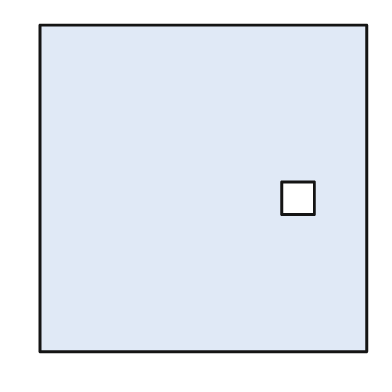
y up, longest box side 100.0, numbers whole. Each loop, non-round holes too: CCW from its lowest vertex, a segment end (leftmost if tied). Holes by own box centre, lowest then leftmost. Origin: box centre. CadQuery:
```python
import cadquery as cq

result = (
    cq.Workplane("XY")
    .moveTo(-50.0, -50.0)
    .lineTo(50.0, -50.0)
    .lineTo(50.0, 50.0)
    .lineTo(-50.0, 50.0)
    .close()
    .moveTo(24.0, -8.0)
    .lineTo(34.0, -8.0)
    .lineTo(34.0, 2.0)
    .lineTo(24.0, 2.0)
    .close()
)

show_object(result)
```